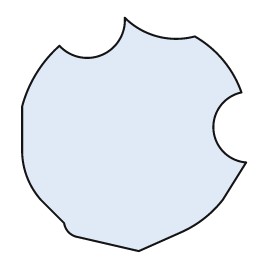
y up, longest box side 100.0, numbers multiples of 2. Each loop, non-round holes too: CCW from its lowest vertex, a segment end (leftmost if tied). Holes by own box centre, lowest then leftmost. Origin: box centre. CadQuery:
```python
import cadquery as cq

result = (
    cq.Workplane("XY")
    .moveTo(2.0, -50.0)
    .lineTo(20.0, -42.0)
    .threePointArc((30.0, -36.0), (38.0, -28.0))
    .lineTo(48.0, -12.0)
    .threePointArc((34.0, 2.0), (46.0, 18.0))
    .threePointArc((38.0, 32.0), (26.0, 42.0))
    .threePointArc((10.0, 42.0), (-4.0, 50.0))
    .threePointArc((-14.0, 34.0), (-32.0, 38.0))
    .threePointArc((-42.0, 26.0), (-48.0, 12.0))
    .lineTo(-48.0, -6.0)
    .threePointArc((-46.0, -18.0), (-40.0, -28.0))
    .lineTo(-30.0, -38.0)
    .threePointArc((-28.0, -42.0), (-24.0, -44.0))
    .close()
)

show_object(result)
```